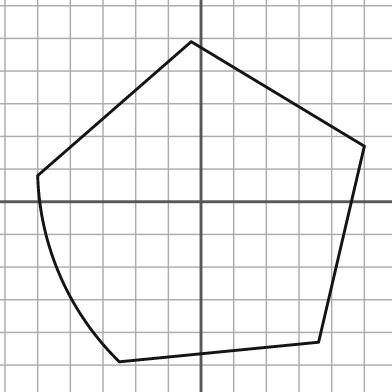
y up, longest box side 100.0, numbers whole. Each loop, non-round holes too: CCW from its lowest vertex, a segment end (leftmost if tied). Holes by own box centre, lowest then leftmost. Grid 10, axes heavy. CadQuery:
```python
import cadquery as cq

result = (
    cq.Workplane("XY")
    .moveTo(-25.0, -49.0)
    .lineTo(36.0, -43.0)
    .lineTo(50.0, 17.0)
    .lineTo(-3.0, 49.0)
    .lineTo(-50.0, 8.0)
    .threePointArc((-43.0, -23.0), (-25.0, -49.0))
    .close()
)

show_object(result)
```